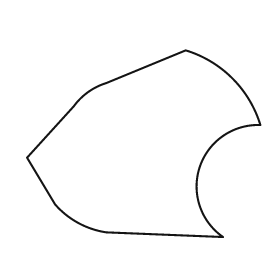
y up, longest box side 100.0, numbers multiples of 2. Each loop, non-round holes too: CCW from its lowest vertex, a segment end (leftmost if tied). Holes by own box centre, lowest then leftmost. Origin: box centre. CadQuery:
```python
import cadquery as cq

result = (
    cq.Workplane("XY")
    .moveTo(34.0, -40.0)
    .threePointArc((24.0, -10.0), (50.0, 8.0))
    .threePointArc((38.0, 28.0), (18.0, 40.0))
    .lineTo(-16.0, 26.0)
    .threePointArc((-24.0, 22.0), (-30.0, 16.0))
    .lineTo(-50.0, -6.0)
    .lineTo(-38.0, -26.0)
    .threePointArc((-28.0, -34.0), (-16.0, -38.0))
    .close()
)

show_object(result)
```